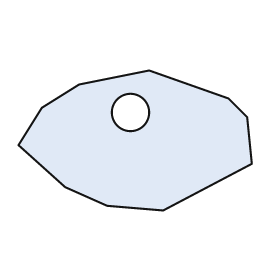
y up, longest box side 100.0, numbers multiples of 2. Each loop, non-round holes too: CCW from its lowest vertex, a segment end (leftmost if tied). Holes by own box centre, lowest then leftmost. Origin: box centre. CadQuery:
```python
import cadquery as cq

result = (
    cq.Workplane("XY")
    .moveTo(12.0, -30.0)
    .lineTo(50.0, -10.0)
    .lineTo(48.0, 10.0)
    .lineTo(40.0, 18.0)
    .lineTo(6.0, 30.0)
    .lineTo(-24.0, 24.0)
    .lineTo(-40.0, 14.0)
    .lineTo(-50.0, -2.0)
    .lineTo(-30.0, -20.0)
    .lineTo(-12.0, -28.0)
    .close()
    .moveTo(-2.0, 12.0)
    .circle(8.0)
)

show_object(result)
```